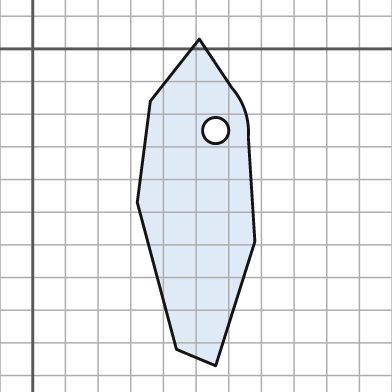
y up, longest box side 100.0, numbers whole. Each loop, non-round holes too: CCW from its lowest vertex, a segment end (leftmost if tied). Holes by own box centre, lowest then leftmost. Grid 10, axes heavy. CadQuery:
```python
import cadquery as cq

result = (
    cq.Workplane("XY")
    .moveTo(56.0, -97.0)
    .lineTo(68.0, -59.0)
    .lineTo(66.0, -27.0)
    .threePointArc((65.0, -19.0), (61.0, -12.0))
    .lineTo(51.0, 3.0)
    .lineTo(36.0, -16.0)
    .lineTo(32.0, -47.0)
    .lineTo(44.0, -92.0)
    .close()
    .moveTo(56.0, -25.0)
    .circle(4.0)
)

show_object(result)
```